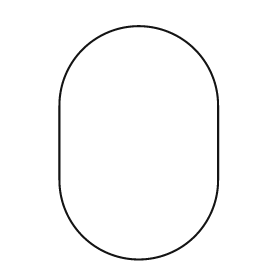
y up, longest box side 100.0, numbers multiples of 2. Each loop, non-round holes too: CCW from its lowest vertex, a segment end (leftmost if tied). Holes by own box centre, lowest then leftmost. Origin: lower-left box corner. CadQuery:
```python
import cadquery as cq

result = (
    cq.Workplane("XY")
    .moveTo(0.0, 34.0)
    .threePointArc((34.0, 0.0), (68.0, 34.0))
    .lineTo(68.0, 66.0)
    .threePointArc((34.0, 100.0), (0.0, 66.0))
    .close()
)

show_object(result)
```